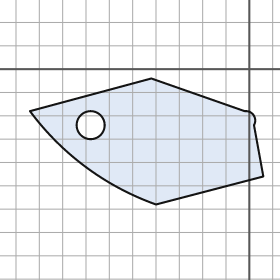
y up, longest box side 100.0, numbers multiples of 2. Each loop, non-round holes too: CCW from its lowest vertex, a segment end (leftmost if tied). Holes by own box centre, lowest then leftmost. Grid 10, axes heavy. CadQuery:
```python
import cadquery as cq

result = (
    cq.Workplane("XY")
    .moveTo(-40.0, -58.0)
    .lineTo(6.0, -46.0)
    .lineTo(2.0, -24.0)
    .threePointArc((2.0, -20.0), (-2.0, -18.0))
    .lineTo(-42.0, -4.0)
    .lineTo(-94.0, -18.0)
    .threePointArc((-70.0, -42.0), (-40.0, -58.0))
    .close()
    .moveTo(-68.0, -24.0)
    .circle(6.0)
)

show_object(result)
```